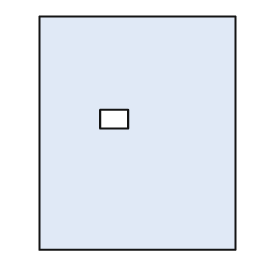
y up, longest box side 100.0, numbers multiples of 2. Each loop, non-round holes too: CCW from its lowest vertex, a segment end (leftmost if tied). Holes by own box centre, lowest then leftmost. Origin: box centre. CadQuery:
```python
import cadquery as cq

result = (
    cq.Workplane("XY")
    .moveTo(-42.0, -50.0)
    .lineTo(42.0, -50.0)
    .lineTo(42.0, 50.0)
    .lineTo(-42.0, 50.0)
    .close()
    .moveTo(-16.0, 2.0)
    .lineTo(-4.0, 2.0)
    .lineTo(-4.0, 10.0)
    .lineTo(-16.0, 10.0)
    .close()
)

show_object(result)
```